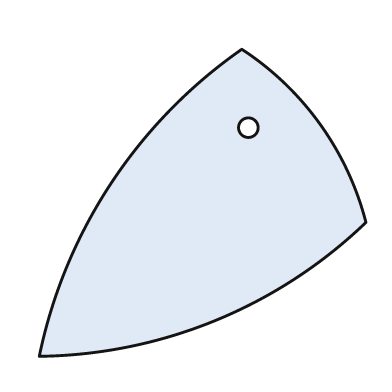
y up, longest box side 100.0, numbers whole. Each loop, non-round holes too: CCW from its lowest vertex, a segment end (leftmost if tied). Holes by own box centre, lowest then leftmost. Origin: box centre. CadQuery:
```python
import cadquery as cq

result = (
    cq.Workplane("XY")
    .moveTo(-50.0, -47.0)
    .threePointArc((4.0, -36.0), (50.0, -6.0))
    .threePointArc((36.0, 24.0), (12.0, 47.0))
    .threePointArc((-28.0, 6.0), (-50.0, -47.0))
    .close()
    .moveTo(14.0, 23.0)
    .circle(3.0)
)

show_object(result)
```